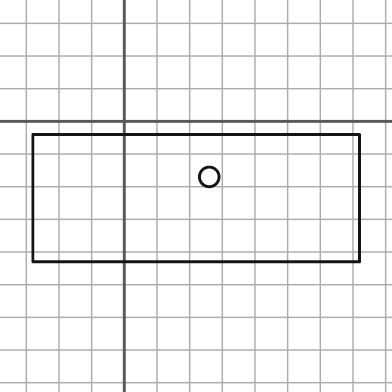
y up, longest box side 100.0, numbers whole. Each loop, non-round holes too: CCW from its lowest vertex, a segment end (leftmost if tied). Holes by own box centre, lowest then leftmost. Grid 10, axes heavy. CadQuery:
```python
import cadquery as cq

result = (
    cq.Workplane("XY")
    .moveTo(-28.0, -43.0)
    .lineTo(72.0, -43.0)
    .lineTo(72.0, -4.0)
    .lineTo(-28.0, -4.0)
    .close()
    .moveTo(26.0, -17.0)
    .circle(3.0)
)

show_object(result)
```